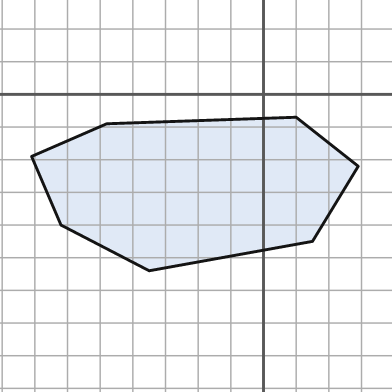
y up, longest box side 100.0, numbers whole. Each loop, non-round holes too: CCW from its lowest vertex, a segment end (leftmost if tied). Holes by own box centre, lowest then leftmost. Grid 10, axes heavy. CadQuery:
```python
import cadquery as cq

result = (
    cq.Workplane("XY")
    .moveTo(-35.0, -54.0)
    .lineTo(15.0, -45.0)
    .lineTo(29.0, -22.0)
    .lineTo(10.0, -7.0)
    .lineTo(-48.0, -9.0)
    .lineTo(-71.0, -19.0)
    .lineTo(-62.0, -40.0)
    .close()
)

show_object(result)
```